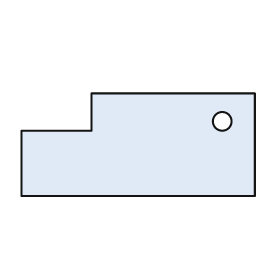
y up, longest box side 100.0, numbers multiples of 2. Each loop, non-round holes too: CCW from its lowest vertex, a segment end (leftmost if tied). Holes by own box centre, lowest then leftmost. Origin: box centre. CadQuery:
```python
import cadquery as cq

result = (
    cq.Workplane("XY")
    .moveTo(-50.0, -22.0)
    .lineTo(50.0, -22.0)
    .lineTo(50.0, 22.0)
    .lineTo(-20.0, 22.0)
    .lineTo(-20.0, 6.0)
    .lineTo(-50.0, 6.0)
    .close()
    .moveTo(36.0, 10.0)
    .circle(4.0)
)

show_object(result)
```